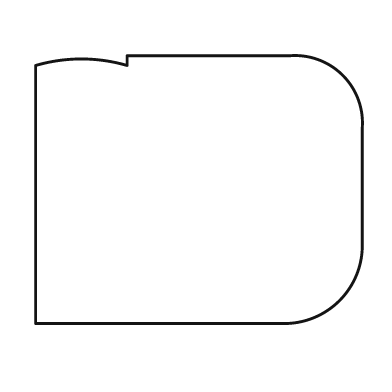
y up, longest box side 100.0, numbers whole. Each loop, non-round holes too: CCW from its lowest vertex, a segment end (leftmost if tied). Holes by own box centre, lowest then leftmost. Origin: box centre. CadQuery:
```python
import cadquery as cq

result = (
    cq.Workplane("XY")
    .moveTo(-50.0, -41.0)
    .lineTo(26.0, -41.0)
    .threePointArc((43.0, -34.0), (50.0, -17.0))
    .lineTo(50.0, 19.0)
    .threePointArc((44.0, 35.0), (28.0, 41.0))
    .lineTo(-22.0, 41.0)
    .lineTo(-22.0, 38.0)
    .threePointArc((-36.0, 40.0), (-50.0, 38.0))
    .close()
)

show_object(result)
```